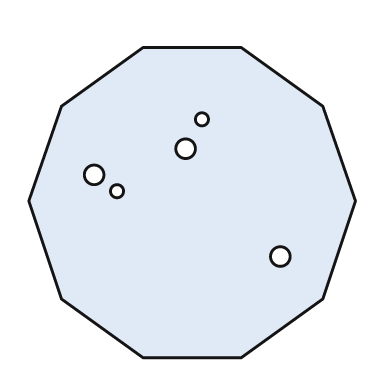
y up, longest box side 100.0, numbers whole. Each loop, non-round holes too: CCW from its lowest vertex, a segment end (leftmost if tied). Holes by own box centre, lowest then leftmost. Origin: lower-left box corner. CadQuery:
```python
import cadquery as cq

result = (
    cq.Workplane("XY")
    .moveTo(35.0, 0.0)
    .lineTo(65.0, 0.0)
    .lineTo(90.0, 18.0)
    .lineTo(100.0, 48.0)
    .lineTo(90.0, 77.0)
    .lineTo(65.0, 95.0)
    .lineTo(35.0, 95.0)
    .lineTo(10.0, 77.0)
    .lineTo(0.0, 48.0)
    .lineTo(10.0, 18.0)
    .close()
    .moveTo(77.0, 31.0)
    .circle(3.0)
    .moveTo(27.0, 51.0)
    .circle(2.0)
    .moveTo(20.0, 56.0)
    .circle(3.0)
    .moveTo(48.0, 64.0)
    .circle(3.0)
    .moveTo(53.0, 73.0)
    .circle(2.0)
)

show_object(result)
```